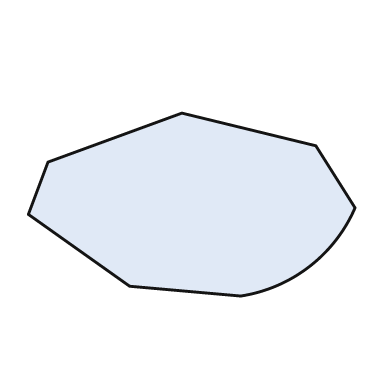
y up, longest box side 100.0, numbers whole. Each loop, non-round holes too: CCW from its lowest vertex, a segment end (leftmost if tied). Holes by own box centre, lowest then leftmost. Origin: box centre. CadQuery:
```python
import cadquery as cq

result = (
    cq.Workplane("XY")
    .moveTo(15.0, -28.0)
    .threePointArc((36.0, -19.0), (50.0, -1.0))
    .lineTo(38.0, 18.0)
    .lineTo(-3.0, 28.0)
    .lineTo(-44.0, 13.0)
    .lineTo(-50.0, -3.0)
    .lineTo(-19.0, -25.0)
    .close()
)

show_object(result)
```